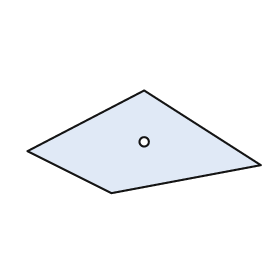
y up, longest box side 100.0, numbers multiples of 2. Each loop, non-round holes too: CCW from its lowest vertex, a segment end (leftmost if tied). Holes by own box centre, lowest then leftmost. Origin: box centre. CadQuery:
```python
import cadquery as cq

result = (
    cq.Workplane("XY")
    .moveTo(-14.0, -22.0)
    .lineTo(50.0, -10.0)
    .lineTo(0.0, 22.0)
    .lineTo(-50.0, -4.0)
    .close()
    .moveTo(0.0, 0.0)
    .circle(2.0)
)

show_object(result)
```